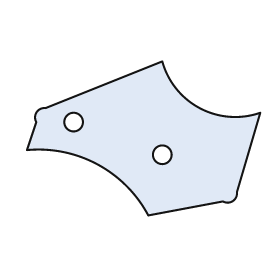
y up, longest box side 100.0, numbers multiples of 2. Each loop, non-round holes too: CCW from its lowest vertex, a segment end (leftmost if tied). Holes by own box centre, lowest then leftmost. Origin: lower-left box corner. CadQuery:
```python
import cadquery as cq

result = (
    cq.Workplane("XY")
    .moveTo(52.0, 0.0)
    .lineTo(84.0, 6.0)
    .threePointArc((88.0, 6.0), (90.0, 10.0))
    .lineTo(100.0, 44.0)
    .threePointArc((74.0, 46.0), (58.0, 66.0))
    .lineTo(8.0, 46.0)
    .threePointArc((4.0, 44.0), (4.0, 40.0))
    .lineTo(0.0, 28.0)
    .threePointArc((30.0, 22.0), (52.0, 0.0))
    .close()
    .moveTo(58.0, 26.0)
    .circle(4.0)
    .moveTo(20.0, 40.0)
    .circle(4.0)
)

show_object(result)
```